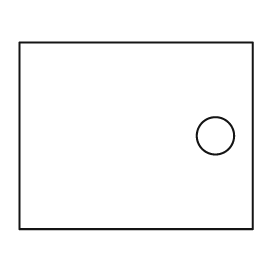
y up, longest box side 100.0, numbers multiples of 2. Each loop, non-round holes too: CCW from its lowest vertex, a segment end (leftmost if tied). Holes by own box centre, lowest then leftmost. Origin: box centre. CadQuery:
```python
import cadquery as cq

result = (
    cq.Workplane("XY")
    .moveTo(-50.0, -40.0)
    .lineTo(50.0, -40.0)
    .lineTo(50.0, 40.0)
    .lineTo(-50.0, 40.0)
    .close()
    .moveTo(34.0, 0.0)
    .circle(8.0)
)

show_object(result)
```